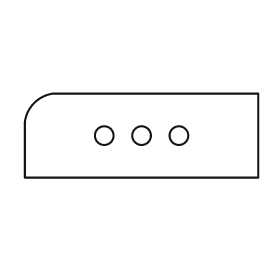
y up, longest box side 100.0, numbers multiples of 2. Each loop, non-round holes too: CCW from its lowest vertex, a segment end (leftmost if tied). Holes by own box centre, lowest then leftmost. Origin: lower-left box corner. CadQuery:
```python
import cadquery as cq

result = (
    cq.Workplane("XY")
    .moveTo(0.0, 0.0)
    .lineTo(100.0, 0.0)
    .lineTo(100.0, 36.0)
    .lineTo(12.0, 36.0)
    .threePointArc((4.0, 32.0), (0.0, 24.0))
    .close()
    .moveTo(34.0, 18.0)
    .circle(4.0)
    .moveTo(50.0, 18.0)
    .circle(4.0)
    .moveTo(66.0, 18.0)
    .circle(4.0)
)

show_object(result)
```